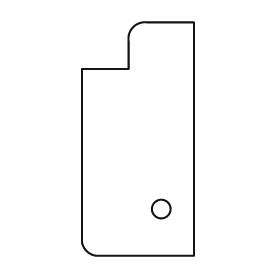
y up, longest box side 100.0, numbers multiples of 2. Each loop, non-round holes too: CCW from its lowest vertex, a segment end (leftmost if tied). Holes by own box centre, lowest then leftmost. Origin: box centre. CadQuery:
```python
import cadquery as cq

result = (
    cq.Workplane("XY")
    .moveTo(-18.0, -50.0)
    .lineTo(24.0, -50.0)
    .lineTo(24.0, 50.0)
    .lineTo(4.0, 50.0)
    .threePointArc((-2.0, 48.0), (-4.0, 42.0))
    .lineTo(-4.0, 30.0)
    .lineTo(-24.0, 30.0)
    .lineTo(-24.0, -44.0)
    .threePointArc((-22.0, -48.0), (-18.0, -50.0))
    .close()
    .moveTo(10.0, -30.0)
    .circle(4.0)
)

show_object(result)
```